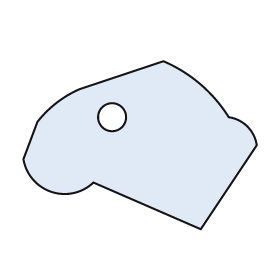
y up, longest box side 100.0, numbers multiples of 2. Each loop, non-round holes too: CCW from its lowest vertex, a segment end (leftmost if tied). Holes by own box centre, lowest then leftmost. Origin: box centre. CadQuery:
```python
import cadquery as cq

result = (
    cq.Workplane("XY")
    .moveTo(26.0, -36.0)
    .lineTo(50.0, 0.0)
    .threePointArc((46.0, 8.0), (38.0, 12.0))
    .threePointArc((26.0, 26.0), (10.0, 36.0))
    .lineTo(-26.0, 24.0)
    .threePointArc((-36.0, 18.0), (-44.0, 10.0))
    .lineTo(-50.0, -6.0)
    .threePointArc((-38.0, -20.0), (-20.0, -16.0))
    .close()
    .moveTo(-12.0, 12.0)
    .circle(6.0)
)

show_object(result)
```